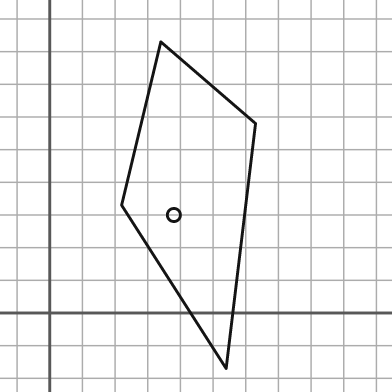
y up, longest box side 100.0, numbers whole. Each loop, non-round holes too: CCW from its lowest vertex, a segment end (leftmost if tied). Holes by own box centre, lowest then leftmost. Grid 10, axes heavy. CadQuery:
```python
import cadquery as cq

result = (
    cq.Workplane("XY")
    .moveTo(54.0, -17.0)
    .lineTo(63.0, 58.0)
    .lineTo(34.0, 83.0)
    .lineTo(22.0, 33.0)
    .close()
    .moveTo(38.0, 30.0)
    .circle(2.0)
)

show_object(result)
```